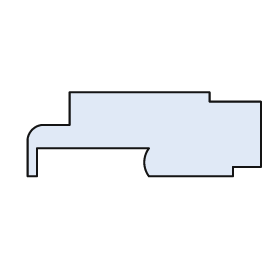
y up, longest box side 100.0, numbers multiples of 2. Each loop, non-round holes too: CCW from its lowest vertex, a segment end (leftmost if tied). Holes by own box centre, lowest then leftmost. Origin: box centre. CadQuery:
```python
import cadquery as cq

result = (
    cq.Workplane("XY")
    .moveTo(-50.0, -18.0)
    .lineTo(-46.0, -18.0)
    .lineTo(-46.0, -6.0)
    .lineTo(2.0, -6.0)
    .threePointArc((0.0, -12.0), (2.0, -18.0))
    .lineTo(38.0, -18.0)
    .lineTo(38.0, -14.0)
    .lineTo(50.0, -14.0)
    .lineTo(50.0, 14.0)
    .lineTo(28.0, 14.0)
    .lineTo(28.0, 18.0)
    .lineTo(-32.0, 18.0)
    .lineTo(-32.0, 4.0)
    .lineTo(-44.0, 4.0)
    .threePointArc((-48.0, 2.0), (-50.0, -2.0))
    .close()
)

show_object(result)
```